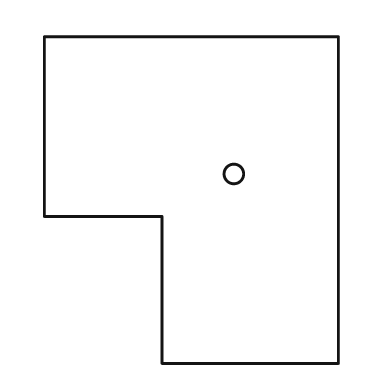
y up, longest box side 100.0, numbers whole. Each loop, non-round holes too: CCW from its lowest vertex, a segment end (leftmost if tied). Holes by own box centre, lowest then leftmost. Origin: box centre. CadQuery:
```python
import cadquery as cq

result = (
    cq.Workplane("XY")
    .moveTo(-9.0, -50.0)
    .lineTo(45.0, -50.0)
    .lineTo(45.0, 50.0)
    .lineTo(-45.0, 50.0)
    .lineTo(-45.0, -5.0)
    .lineTo(-9.0, -5.0)
    .close()
    .moveTo(13.0, 8.0)
    .circle(3.0)
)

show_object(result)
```